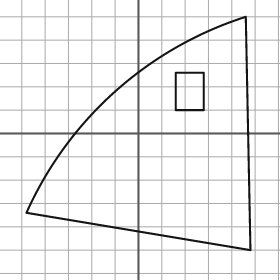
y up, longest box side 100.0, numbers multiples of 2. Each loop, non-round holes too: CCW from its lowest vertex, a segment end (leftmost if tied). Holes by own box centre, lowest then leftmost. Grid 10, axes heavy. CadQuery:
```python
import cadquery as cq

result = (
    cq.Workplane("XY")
    .moveTo(48.0, -50.0)
    .lineTo(46.0, 50.0)
    .threePointArc((-10.0, 18.0), (-48.0, -34.0))
    .close()
    .moveTo(16.0, 10.0)
    .lineTo(28.0, 10.0)
    .lineTo(28.0, 26.0)
    .lineTo(16.0, 26.0)
    .close()
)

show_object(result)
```